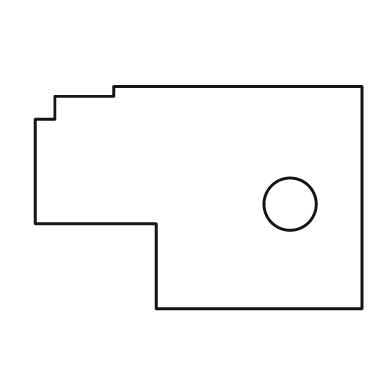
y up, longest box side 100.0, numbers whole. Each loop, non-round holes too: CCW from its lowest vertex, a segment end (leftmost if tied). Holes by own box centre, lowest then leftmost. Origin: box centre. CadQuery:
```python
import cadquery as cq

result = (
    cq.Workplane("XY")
    .moveTo(-13.0, -34.0)
    .lineTo(50.0, -34.0)
    .lineTo(50.0, 34.0)
    .lineTo(-26.0, 34.0)
    .lineTo(-26.0, 31.0)
    .lineTo(-44.0, 31.0)
    .lineTo(-44.0, 24.0)
    .lineTo(-50.0, 24.0)
    .lineTo(-50.0, -8.0)
    .lineTo(-13.0, -8.0)
    .close()
    .moveTo(28.0, -2.0)
    .circle(8.0)
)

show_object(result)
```